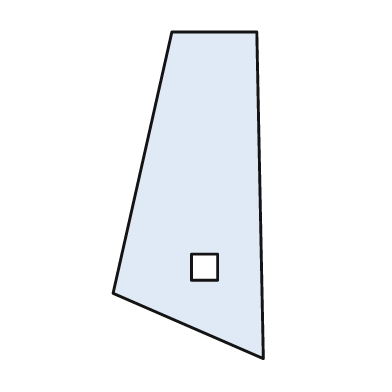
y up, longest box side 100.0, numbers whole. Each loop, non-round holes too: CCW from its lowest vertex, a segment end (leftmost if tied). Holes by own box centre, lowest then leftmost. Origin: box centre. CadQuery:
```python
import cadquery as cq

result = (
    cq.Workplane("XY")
    .moveTo(23.0, -50.0)
    .lineTo(21.0, 50.0)
    .lineTo(-5.0, 50.0)
    .lineTo(-23.0, -30.0)
    .close()
    .moveTo(1.0, -26.0)
    .lineTo(9.0, -26.0)
    .lineTo(9.0, -18.0)
    .lineTo(1.0, -18.0)
    .close()
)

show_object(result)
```